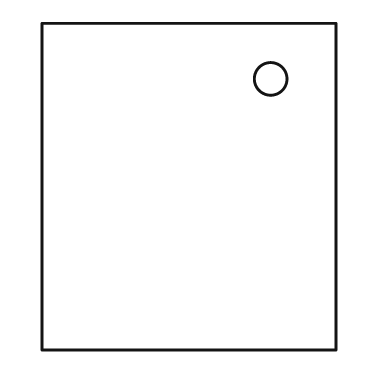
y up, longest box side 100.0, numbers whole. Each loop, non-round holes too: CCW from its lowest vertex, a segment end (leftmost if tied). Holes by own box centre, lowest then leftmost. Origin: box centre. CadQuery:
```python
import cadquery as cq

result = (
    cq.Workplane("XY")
    .moveTo(-45.0, -50.0)
    .lineTo(45.0, -50.0)
    .lineTo(45.0, 50.0)
    .lineTo(-45.0, 50.0)
    .close()
    .moveTo(25.0, 33.0)
    .circle(5.0)
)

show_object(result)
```